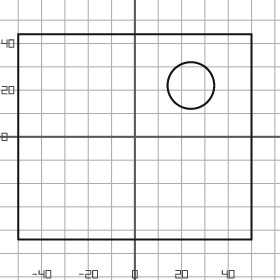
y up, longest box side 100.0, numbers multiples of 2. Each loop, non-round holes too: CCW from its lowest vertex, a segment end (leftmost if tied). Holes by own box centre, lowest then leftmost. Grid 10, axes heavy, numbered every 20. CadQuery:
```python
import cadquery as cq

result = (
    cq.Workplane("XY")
    .moveTo(-50.0, -44.0)
    .lineTo(50.0, -44.0)
    .lineTo(50.0, 44.0)
    .lineTo(-50.0, 44.0)
    .close()
    .moveTo(24.0, 22.0)
    .circle(10.0)
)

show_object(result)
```